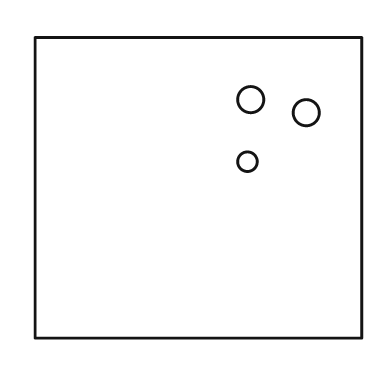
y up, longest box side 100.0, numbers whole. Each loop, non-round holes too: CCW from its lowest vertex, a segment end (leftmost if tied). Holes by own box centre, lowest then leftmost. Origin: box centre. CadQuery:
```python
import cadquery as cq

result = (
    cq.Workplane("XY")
    .moveTo(-50.0, -46.0)
    .lineTo(50.0, -46.0)
    .lineTo(50.0, 46.0)
    .lineTo(-50.0, 46.0)
    .close()
    .moveTo(15.0, 8.0)
    .circle(3.0)
    .moveTo(33.0, 23.0)
    .circle(4.0)
    .moveTo(16.0, 27.0)
    .circle(4.0)
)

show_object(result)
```